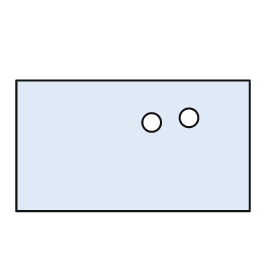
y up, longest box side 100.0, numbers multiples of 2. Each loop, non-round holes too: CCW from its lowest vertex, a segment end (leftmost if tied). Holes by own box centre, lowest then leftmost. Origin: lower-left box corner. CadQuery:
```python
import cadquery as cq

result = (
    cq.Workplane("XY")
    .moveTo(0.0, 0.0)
    .lineTo(100.0, 0.0)
    .lineTo(100.0, 56.0)
    .lineTo(0.0, 56.0)
    .close()
    .moveTo(58.0, 38.0)
    .circle(4.0)
    .moveTo(74.0, 40.0)
    .circle(4.0)
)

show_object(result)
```